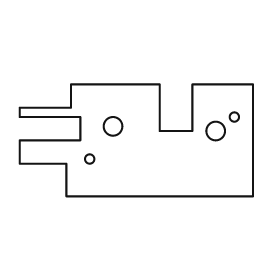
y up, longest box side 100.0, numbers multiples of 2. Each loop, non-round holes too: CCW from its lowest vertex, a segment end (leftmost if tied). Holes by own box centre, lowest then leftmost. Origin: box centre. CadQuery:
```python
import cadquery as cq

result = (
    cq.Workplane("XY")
    .moveTo(-30.0, -24.0)
    .lineTo(50.0, -24.0)
    .lineTo(50.0, 24.0)
    .lineTo(24.0, 24.0)
    .lineTo(24.0, 4.0)
    .lineTo(10.0, 4.0)
    .lineTo(10.0, 24.0)
    .lineTo(-28.0, 24.0)
    .lineTo(-28.0, 14.0)
    .lineTo(-50.0, 14.0)
    .lineTo(-50.0, 10.0)
    .lineTo(-24.0, 10.0)
    .lineTo(-24.0, 0.0)
    .lineTo(-50.0, 0.0)
    .lineTo(-50.0, -10.0)
    .lineTo(-30.0, -10.0)
    .close()
    .moveTo(-20.0, -8.0)
    .circle(2.0)
    .moveTo(34.0, 4.0)
    .circle(4.0)
    .moveTo(-10.0, 6.0)
    .circle(4.0)
    .moveTo(42.0, 10.0)
    .circle(2.0)
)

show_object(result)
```